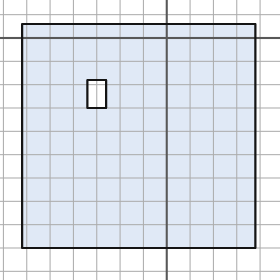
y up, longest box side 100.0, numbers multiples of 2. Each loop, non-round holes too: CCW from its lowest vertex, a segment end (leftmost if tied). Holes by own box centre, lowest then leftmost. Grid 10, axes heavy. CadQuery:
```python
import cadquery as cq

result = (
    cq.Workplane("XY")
    .moveTo(-62.0, -90.0)
    .lineTo(38.0, -90.0)
    .lineTo(38.0, 6.0)
    .lineTo(-62.0, 6.0)
    .close()
    .moveTo(-34.0, -30.0)
    .lineTo(-26.0, -30.0)
    .lineTo(-26.0, -18.0)
    .lineTo(-34.0, -18.0)
    .close()
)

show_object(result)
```